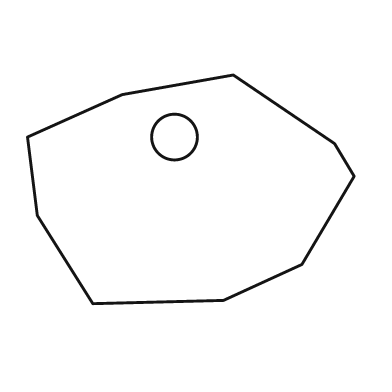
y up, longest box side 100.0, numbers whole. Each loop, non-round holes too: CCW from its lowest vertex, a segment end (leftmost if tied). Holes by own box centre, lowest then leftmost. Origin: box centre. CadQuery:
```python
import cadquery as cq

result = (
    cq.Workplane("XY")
    .moveTo(-30.0, -35.0)
    .lineTo(10.0, -34.0)
    .lineTo(34.0, -23.0)
    .lineTo(50.0, 4.0)
    .lineTo(44.0, 14.0)
    .lineTo(13.0, 35.0)
    .lineTo(-21.0, 29.0)
    .lineTo(-50.0, 16.0)
    .lineTo(-47.0, -8.0)
    .close()
    .moveTo(-5.0, 16.0)
    .circle(7.0)
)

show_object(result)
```